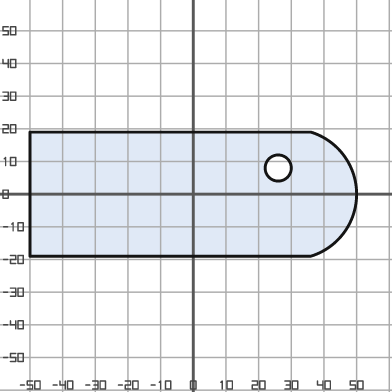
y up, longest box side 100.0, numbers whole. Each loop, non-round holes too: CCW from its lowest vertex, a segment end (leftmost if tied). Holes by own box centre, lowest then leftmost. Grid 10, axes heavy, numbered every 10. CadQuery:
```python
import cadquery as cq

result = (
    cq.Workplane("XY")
    .moveTo(-50.0, -19.0)
    .lineTo(36.0, -19.0)
    .threePointArc((50.0, 0.0), (36.0, 19.0))
    .lineTo(-50.0, 19.0)
    .close()
    .moveTo(26.0, 8.0)
    .circle(4.0)
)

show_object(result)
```